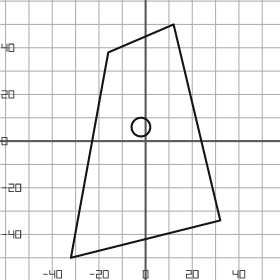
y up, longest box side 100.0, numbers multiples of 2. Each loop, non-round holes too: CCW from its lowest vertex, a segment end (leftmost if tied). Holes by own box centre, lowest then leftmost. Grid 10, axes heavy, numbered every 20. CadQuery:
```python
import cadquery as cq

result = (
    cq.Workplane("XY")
    .moveTo(-32.0, -50.0)
    .lineTo(32.0, -34.0)
    .lineTo(12.0, 50.0)
    .lineTo(-16.0, 38.0)
    .close()
    .moveTo(-2.0, 6.0)
    .circle(4.0)
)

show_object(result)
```